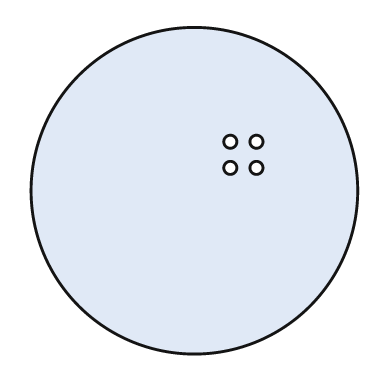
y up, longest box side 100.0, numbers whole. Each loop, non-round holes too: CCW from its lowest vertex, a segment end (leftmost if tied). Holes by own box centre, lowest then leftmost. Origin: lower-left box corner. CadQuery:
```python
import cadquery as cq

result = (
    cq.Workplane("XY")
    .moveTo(50.0, 50.0)
    .circle(50.0)
    .moveTo(61.0, 57.0)
    .circle(2.0)
    .moveTo(69.0, 57.0)
    .circle(2.0)
    .moveTo(61.0, 65.0)
    .circle(2.0)
    .moveTo(69.0, 65.0)
    .circle(2.0)
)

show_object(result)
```